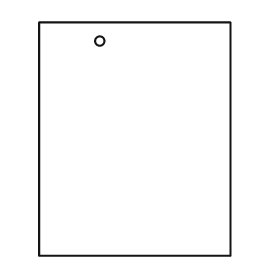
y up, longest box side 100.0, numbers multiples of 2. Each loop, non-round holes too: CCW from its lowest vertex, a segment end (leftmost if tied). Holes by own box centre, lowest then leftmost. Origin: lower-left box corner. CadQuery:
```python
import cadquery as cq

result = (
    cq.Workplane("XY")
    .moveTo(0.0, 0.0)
    .lineTo(82.0, 0.0)
    .lineTo(82.0, 100.0)
    .lineTo(0.0, 100.0)
    .close()
    .moveTo(26.0, 92.0)
    .circle(2.0)
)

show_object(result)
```